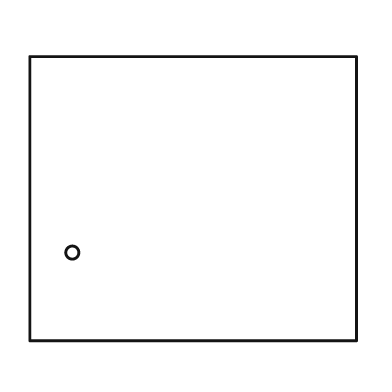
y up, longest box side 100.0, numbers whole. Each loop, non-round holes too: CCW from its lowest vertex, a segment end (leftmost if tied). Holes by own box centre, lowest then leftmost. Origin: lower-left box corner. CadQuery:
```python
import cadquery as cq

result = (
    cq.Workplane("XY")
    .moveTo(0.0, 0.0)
    .lineTo(100.0, 0.0)
    .lineTo(100.0, 87.0)
    .lineTo(0.0, 87.0)
    .close()
    .moveTo(13.0, 27.0)
    .circle(2.0)
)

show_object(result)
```